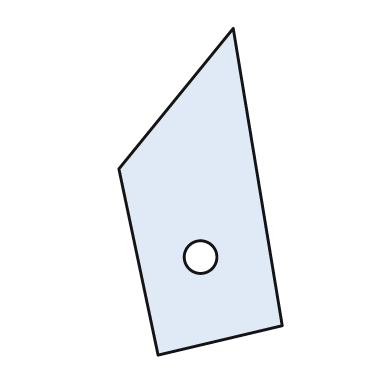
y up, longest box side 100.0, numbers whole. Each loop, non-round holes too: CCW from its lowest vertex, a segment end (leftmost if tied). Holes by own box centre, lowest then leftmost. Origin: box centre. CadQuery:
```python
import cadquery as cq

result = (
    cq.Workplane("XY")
    .moveTo(-13.0, -50.0)
    .lineTo(25.0, -41.0)
    .lineTo(10.0, 50.0)
    .lineTo(-25.0, 7.0)
    .close()
    .moveTo(0.0, -20.0)
    .circle(5.0)
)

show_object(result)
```